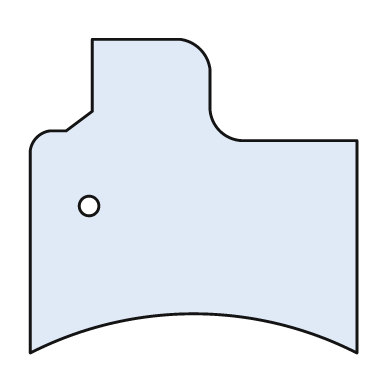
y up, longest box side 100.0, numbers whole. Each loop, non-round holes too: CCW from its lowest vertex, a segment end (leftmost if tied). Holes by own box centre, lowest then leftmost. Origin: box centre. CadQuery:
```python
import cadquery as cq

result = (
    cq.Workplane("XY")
    .moveTo(-50.0, -48.0)
    .threePointArc((0.0, -36.0), (50.0, -48.0))
    .lineTo(50.0, 17.0)
    .lineTo(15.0, 17.0)
    .threePointArc((8.0, 20.0), (5.0, 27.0))
    .lineTo(5.0, 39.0)
    .threePointArc((2.0, 45.0), (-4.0, 48.0))
    .lineTo(-31.0, 48.0)
    .lineTo(-31.0, 26.0)
    .lineTo(-39.0, 20.0)
    .lineTo(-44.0, 20.0)
    .threePointArc((-48.0, 18.0), (-50.0, 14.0))
    .close()
    .moveTo(-32.0, -3.0)
    .circle(3.0)
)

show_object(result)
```